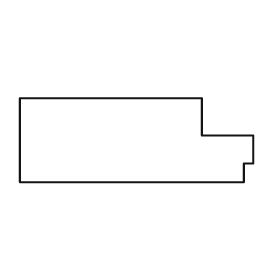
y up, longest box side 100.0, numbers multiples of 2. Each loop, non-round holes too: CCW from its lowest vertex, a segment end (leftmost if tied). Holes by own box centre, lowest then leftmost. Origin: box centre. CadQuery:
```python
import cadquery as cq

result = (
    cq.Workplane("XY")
    .moveTo(-50.0, -18.0)
    .lineTo(46.0, -18.0)
    .lineTo(46.0, -10.0)
    .lineTo(50.0, -10.0)
    .lineTo(50.0, 2.0)
    .lineTo(28.0, 2.0)
    .lineTo(28.0, 18.0)
    .lineTo(-50.0, 18.0)
    .close()
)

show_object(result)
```